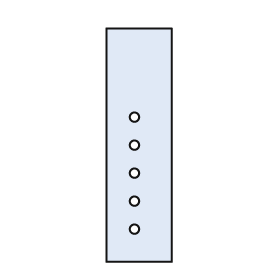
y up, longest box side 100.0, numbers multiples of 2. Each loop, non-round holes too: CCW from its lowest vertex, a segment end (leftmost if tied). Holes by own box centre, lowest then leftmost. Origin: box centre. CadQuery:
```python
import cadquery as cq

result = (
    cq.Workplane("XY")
    .moveTo(-14.0, -50.0)
    .lineTo(14.0, -50.0)
    .lineTo(14.0, 50.0)
    .lineTo(-14.0, 50.0)
    .close()
    .moveTo(-2.0, -36.0)
    .circle(2.0)
    .moveTo(-2.0, -24.0)
    .circle(2.0)
    .moveTo(-2.0, -12.0)
    .circle(2.0)
    .moveTo(-2.0, 0.0)
    .circle(2.0)
    .moveTo(-2.0, 12.0)
    .circle(2.0)
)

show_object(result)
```